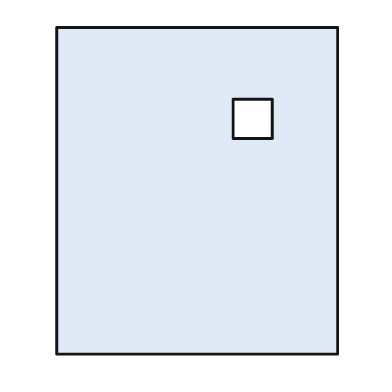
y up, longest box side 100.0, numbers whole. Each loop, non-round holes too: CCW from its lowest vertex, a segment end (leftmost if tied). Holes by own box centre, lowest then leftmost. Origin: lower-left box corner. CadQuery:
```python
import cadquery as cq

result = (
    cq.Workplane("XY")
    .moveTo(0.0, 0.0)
    .lineTo(86.0, 0.0)
    .lineTo(86.0, 100.0)
    .lineTo(0.0, 100.0)
    .close()
    .moveTo(54.0, 66.0)
    .lineTo(66.0, 66.0)
    .lineTo(66.0, 78.0)
    .lineTo(54.0, 78.0)
    .close()
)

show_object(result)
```